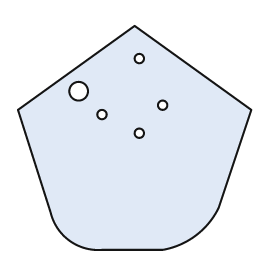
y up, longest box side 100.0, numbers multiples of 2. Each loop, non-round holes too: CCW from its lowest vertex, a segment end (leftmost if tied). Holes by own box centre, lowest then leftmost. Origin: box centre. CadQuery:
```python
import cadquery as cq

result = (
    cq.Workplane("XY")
    .moveTo(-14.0, -48.0)
    .lineTo(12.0, -48.0)
    .threePointArc((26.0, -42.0), (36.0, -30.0))
    .lineTo(50.0, 12.0)
    .lineTo(0.0, 48.0)
    .lineTo(-50.0, 12.0)
    .lineTo(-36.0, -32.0)
    .threePointArc((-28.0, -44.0), (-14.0, -48.0))
    .close()
    .moveTo(2.0, 2.0)
    .circle(2.0)
    .moveTo(-14.0, 10.0)
    .circle(2.0)
    .moveTo(12.0, 14.0)
    .circle(2.0)
    .moveTo(-24.0, 20.0)
    .circle(4.0)
    .moveTo(2.0, 34.0)
    .circle(2.0)
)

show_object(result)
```